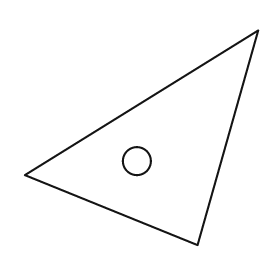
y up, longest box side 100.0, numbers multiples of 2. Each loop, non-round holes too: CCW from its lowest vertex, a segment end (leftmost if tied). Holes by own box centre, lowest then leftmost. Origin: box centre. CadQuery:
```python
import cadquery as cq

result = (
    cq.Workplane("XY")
    .moveTo(24.0, -46.0)
    .lineTo(50.0, 46.0)
    .lineTo(-50.0, -16.0)
    .close()
    .moveTo(-2.0, -10.0)
    .circle(6.0)
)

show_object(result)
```